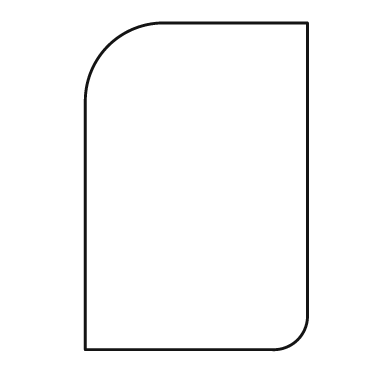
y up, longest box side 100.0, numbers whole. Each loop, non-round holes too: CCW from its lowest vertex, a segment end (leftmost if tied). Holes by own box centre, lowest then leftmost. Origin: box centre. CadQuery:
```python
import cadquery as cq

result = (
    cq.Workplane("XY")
    .moveTo(-34.0, -50.0)
    .lineTo(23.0, -50.0)
    .threePointArc((31.0, -47.0), (34.0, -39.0))
    .lineTo(34.0, 50.0)
    .lineTo(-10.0, 50.0)
    .threePointArc((-27.0, 43.0), (-34.0, 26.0))
    .close()
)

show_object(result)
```